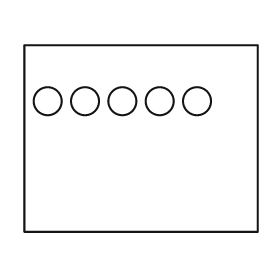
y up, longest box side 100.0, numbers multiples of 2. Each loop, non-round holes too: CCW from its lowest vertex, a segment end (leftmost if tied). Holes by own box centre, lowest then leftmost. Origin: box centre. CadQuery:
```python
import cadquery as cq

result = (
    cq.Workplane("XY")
    .moveTo(-50.0, -40.0)
    .lineTo(50.0, -40.0)
    .lineTo(50.0, 40.0)
    .lineTo(-50.0, 40.0)
    .close()
    .moveTo(-40.0, 16.0)
    .circle(6.0)
    .moveTo(-24.0, 16.0)
    .circle(6.0)
    .moveTo(-8.0, 16.0)
    .circle(6.0)
    .moveTo(8.0, 16.0)
    .circle(6.0)
    .moveTo(24.0, 16.0)
    .circle(6.0)
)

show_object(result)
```